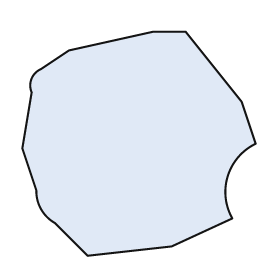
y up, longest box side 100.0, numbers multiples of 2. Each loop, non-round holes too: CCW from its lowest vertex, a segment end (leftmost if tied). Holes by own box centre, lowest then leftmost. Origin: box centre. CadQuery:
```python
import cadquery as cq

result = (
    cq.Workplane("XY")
    .moveTo(-22.0, -48.0)
    .lineTo(14.0, -44.0)
    .lineTo(40.0, -32.0)
    .threePointArc((38.0, -14.0), (50.0, 0.0))
    .lineTo(44.0, 18.0)
    .lineTo(20.0, 48.0)
    .lineTo(6.0, 48.0)
    .lineTo(-30.0, 40.0)
    .lineTo(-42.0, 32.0)
    .threePointArc((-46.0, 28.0), (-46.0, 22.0))
    .lineTo(-50.0, -2.0)
    .lineTo(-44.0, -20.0)
    .threePointArc((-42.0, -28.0), (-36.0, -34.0))
    .close()
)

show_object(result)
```